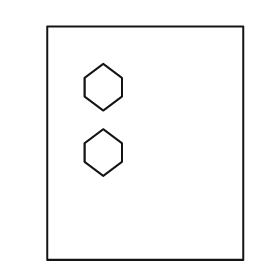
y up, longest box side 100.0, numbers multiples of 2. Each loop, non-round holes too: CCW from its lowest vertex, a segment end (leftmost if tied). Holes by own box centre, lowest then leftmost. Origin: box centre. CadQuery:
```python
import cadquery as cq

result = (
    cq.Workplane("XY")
    .moveTo(-42.0, -50.0)
    .lineTo(42.0, -50.0)
    .lineTo(42.0, 50.0)
    .lineTo(-42.0, 50.0)
    .close()
    .moveTo(-18.0, -14.0)
    .lineTo(-10.0, -8.0)
    .lineTo(-10.0, 0.0)
    .lineTo(-18.0, 6.0)
    .lineTo(-26.0, 0.0)
    .lineTo(-26.0, -8.0)
    .close()
    .moveTo(-18.0, 14.0)
    .lineTo(-10.0, 20.0)
    .lineTo(-10.0, 28.0)
    .lineTo(-18.0, 34.0)
    .lineTo(-26.0, 28.0)
    .lineTo(-26.0, 20.0)
    .close()
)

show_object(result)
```